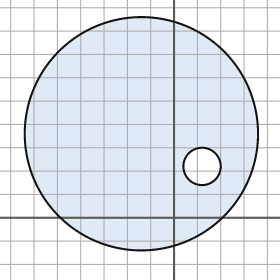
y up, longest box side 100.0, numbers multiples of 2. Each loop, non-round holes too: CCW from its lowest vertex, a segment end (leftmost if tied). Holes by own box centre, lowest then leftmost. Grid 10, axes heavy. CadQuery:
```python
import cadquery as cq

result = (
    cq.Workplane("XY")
    .moveTo(-14.0, 36.0)
    .circle(50.0)
    .moveTo(12.0, 22.0)
    .circle(8.0)
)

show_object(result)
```